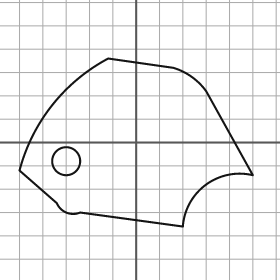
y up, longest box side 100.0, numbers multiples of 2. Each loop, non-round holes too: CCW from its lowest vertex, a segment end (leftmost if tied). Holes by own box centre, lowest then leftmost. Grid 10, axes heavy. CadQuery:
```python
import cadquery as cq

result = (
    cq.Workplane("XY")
    .moveTo(20.0, -36.0)
    .threePointArc((30.0, -18.0), (50.0, -14.0))
    .lineTo(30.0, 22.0)
    .threePointArc((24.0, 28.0), (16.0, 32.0))
    .lineTo(-12.0, 36.0)
    .threePointArc((-36.0, 16.0), (-50.0, -12.0))
    .lineTo(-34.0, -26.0)
    .threePointArc((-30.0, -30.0), (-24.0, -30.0))
    .close()
    .moveTo(-30.0, -8.0)
    .circle(6.0)
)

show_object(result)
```